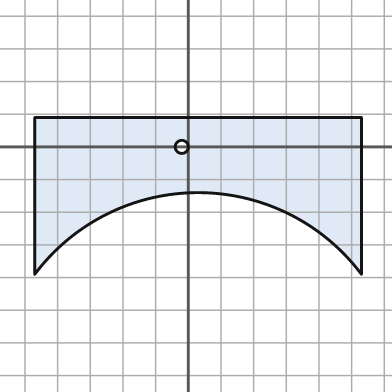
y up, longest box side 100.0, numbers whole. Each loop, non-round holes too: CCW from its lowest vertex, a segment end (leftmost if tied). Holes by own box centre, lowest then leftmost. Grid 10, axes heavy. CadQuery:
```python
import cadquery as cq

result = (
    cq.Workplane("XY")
    .moveTo(-47.0, -39.0)
    .threePointArc((3.0, -14.0), (53.0, -39.0))
    .lineTo(53.0, 9.0)
    .lineTo(-47.0, 9.0)
    .close()
    .moveTo(-2.0, 0.0)
    .circle(2.0)
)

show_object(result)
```